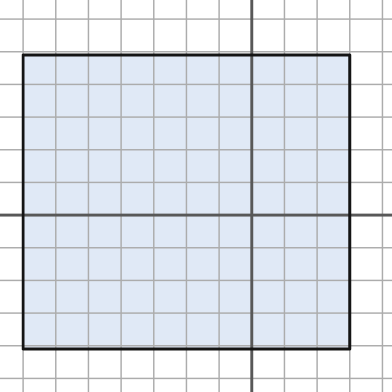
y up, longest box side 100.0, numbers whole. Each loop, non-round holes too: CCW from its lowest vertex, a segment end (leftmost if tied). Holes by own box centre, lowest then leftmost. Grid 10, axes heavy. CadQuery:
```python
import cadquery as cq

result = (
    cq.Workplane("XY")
    .moveTo(-70.0, -41.0)
    .lineTo(30.0, -41.0)
    .lineTo(30.0, 49.0)
    .lineTo(-70.0, 49.0)
    .close()
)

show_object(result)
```